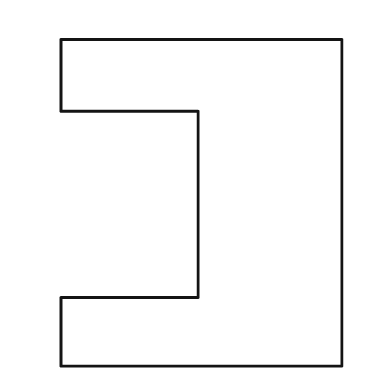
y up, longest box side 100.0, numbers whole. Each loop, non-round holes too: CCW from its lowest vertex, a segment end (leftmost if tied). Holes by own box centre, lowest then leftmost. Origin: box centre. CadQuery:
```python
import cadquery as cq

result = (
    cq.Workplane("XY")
    .moveTo(-43.0, -50.0)
    .lineTo(43.0, -50.0)
    .lineTo(43.0, 50.0)
    .lineTo(-43.0, 50.0)
    .lineTo(-43.0, 28.0)
    .lineTo(-1.0, 28.0)
    .lineTo(-1.0, -29.0)
    .lineTo(-43.0, -29.0)
    .close()
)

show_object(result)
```